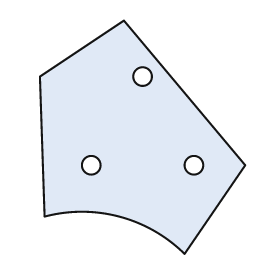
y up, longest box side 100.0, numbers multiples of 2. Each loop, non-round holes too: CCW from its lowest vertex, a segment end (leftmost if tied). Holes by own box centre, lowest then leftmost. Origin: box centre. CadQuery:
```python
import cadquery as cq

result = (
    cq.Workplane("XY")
    .moveTo(18.0, -50.0)
    .lineTo(44.0, -12.0)
    .lineTo(-8.0, 50.0)
    .lineTo(-44.0, 26.0)
    .lineTo(-42.0, -34.0)
    .threePointArc((-10.0, -34.0), (18.0, -50.0))
    .close()
    .moveTo(-22.0, -12.0)
    .circle(4.0)
    .moveTo(22.0, -12.0)
    .circle(4.0)
    .moveTo(0.0, 26.0)
    .circle(4.0)
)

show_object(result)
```